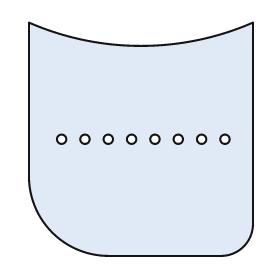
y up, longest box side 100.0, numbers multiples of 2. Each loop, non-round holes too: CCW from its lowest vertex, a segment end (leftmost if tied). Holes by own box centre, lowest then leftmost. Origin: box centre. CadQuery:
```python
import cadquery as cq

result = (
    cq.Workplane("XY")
    .moveTo(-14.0, -50.0)
    .lineTo(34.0, -50.0)
    .threePointArc((44.0, -46.0), (48.0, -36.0))
    .lineTo(48.0, 50.0)
    .threePointArc((0.0, 40.0), (-48.0, 50.0))
    .lineTo(-48.0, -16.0)
    .threePointArc((-38.0, -40.0), (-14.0, -50.0))
    .close()
    .moveTo(-34.0, 0.0)
    .circle(2.0)
    .moveTo(-24.0, 0.0)
    .circle(2.0)
    .moveTo(-14.0, 0.0)
    .circle(2.0)
    .moveTo(-4.0, 0.0)
    .circle(2.0)
    .moveTo(6.0, 0.0)
    .circle(2.0)
    .moveTo(16.0, 0.0)
    .circle(2.0)
    .moveTo(26.0, 0.0)
    .circle(2.0)
    .moveTo(36.0, 0.0)
    .circle(2.0)
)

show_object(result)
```